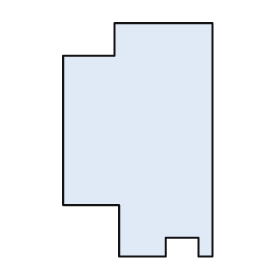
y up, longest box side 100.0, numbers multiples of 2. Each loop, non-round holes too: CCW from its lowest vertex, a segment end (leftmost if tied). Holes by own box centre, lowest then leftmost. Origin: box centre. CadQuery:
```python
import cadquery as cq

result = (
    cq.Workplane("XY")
    .moveTo(-8.0, -50.0)
    .lineTo(12.0, -50.0)
    .lineTo(12.0, -42.0)
    .lineTo(26.0, -42.0)
    .lineTo(26.0, -50.0)
    .lineTo(32.0, -50.0)
    .lineTo(32.0, 50.0)
    .lineTo(-10.0, 50.0)
    .lineTo(-10.0, 36.0)
    .lineTo(-32.0, 36.0)
    .lineTo(-32.0, -28.0)
    .lineTo(-8.0, -28.0)
    .close()
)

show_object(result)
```